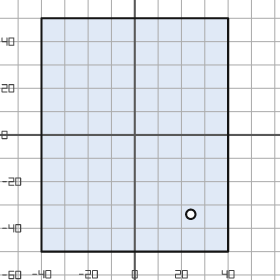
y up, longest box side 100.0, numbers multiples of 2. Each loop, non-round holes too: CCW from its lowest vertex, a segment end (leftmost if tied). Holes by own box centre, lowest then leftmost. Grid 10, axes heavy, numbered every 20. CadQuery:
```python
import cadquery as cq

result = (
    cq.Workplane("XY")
    .moveTo(-40.0, -50.0)
    .lineTo(40.0, -50.0)
    .lineTo(40.0, 50.0)
    .lineTo(-40.0, 50.0)
    .close()
    .moveTo(24.0, -34.0)
    .circle(2.0)
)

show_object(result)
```